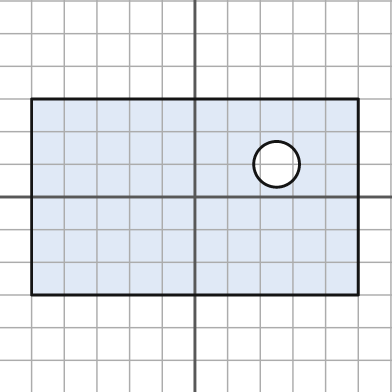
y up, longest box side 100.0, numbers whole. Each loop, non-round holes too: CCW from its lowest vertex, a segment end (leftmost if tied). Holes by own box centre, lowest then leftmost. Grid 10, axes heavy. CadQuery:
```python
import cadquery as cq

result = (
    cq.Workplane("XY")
    .moveTo(-50.0, -30.0)
    .lineTo(50.0, -30.0)
    .lineTo(50.0, 30.0)
    .lineTo(-50.0, 30.0)
    .close()
    .moveTo(25.0, 10.0)
    .circle(7.0)
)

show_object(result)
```